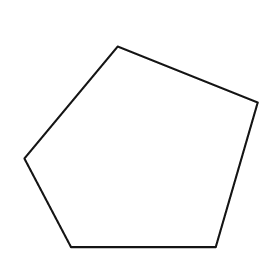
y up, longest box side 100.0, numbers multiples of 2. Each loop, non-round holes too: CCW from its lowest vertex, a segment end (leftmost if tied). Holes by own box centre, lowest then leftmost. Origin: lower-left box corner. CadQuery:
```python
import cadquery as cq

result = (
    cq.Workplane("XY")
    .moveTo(20.0, 0.0)
    .lineTo(82.0, 0.0)
    .lineTo(100.0, 62.0)
    .lineTo(40.0, 86.0)
    .lineTo(0.0, 38.0)
    .close()
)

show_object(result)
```